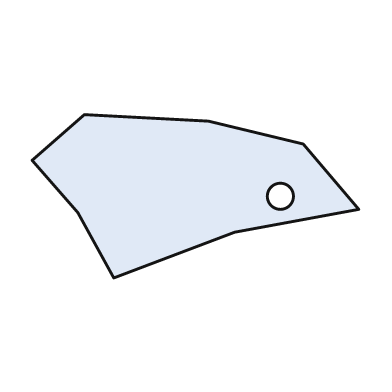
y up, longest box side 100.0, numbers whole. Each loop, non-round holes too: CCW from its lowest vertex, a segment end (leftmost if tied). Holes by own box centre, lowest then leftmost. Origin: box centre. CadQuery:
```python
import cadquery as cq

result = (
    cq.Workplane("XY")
    .moveTo(-25.0, -25.0)
    .lineTo(12.0, -11.0)
    .lineTo(50.0, -4.0)
    .lineTo(33.0, 16.0)
    .lineTo(4.0, 23.0)
    .lineTo(-34.0, 25.0)
    .lineTo(-50.0, 11.0)
    .lineTo(-36.0, -5.0)
    .close()
    .moveTo(26.0, 0.0)
    .circle(4.0)
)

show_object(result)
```